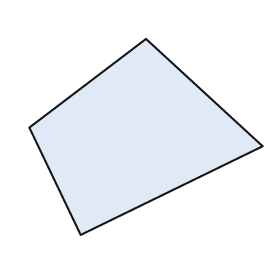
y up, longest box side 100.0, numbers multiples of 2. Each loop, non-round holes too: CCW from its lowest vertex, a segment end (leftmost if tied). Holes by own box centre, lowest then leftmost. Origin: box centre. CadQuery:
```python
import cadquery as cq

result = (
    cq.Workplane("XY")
    .moveTo(-28.0, -42.0)
    .lineTo(50.0, -4.0)
    .lineTo(0.0, 42.0)
    .lineTo(-50.0, 4.0)
    .close()
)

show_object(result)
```